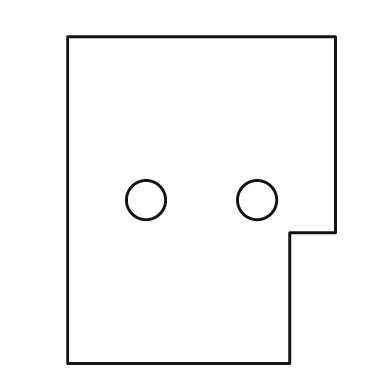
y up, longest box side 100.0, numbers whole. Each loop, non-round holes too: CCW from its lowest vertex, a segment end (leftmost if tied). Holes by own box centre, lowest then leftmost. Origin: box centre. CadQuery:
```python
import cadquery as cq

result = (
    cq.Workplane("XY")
    .moveTo(-41.0, -50.0)
    .lineTo(27.0, -50.0)
    .lineTo(27.0, -10.0)
    .lineTo(41.0, -10.0)
    .lineTo(41.0, 50.0)
    .lineTo(-41.0, 50.0)
    .close()
    .moveTo(-17.0, 0.0)
    .circle(6.0)
    .moveTo(17.0, 0.0)
    .circle(6.0)
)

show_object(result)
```